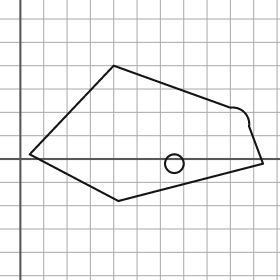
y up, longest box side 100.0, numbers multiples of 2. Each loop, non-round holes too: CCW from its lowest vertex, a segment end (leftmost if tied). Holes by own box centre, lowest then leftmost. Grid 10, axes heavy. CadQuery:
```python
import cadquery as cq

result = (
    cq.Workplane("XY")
    .moveTo(42.0, -18.0)
    .lineTo(104.0, -2.0)
    .lineTo(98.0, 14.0)
    .threePointArc((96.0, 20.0), (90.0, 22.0))
    .lineTo(40.0, 40.0)
    .lineTo(4.0, 2.0)
    .close()
    .moveTo(66.0, -2.0)
    .circle(4.0)
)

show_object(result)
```